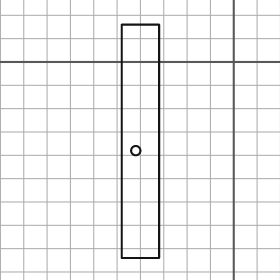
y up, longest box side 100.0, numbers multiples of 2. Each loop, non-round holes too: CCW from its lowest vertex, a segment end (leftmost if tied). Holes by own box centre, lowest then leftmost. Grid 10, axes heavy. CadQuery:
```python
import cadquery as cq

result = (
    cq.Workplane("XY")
    .moveTo(-48.0, -84.0)
    .lineTo(-32.0, -84.0)
    .lineTo(-32.0, 16.0)
    .lineTo(-48.0, 16.0)
    .close()
    .moveTo(-42.0, -38.0)
    .circle(2.0)
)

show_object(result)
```